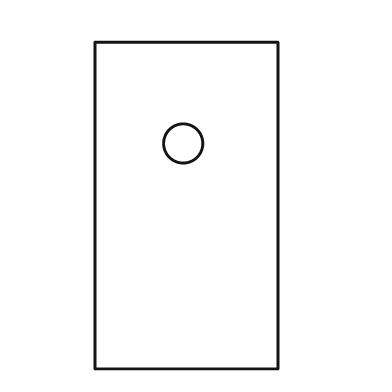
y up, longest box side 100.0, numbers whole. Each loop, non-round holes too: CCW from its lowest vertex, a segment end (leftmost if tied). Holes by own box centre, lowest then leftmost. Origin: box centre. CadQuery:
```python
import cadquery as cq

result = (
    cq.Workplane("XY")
    .moveTo(-28.0, -50.0)
    .lineTo(28.0, -50.0)
    .lineTo(28.0, 50.0)
    .lineTo(-28.0, 50.0)
    .close()
    .moveTo(-1.0, 19.0)
    .circle(6.0)
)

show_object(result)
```